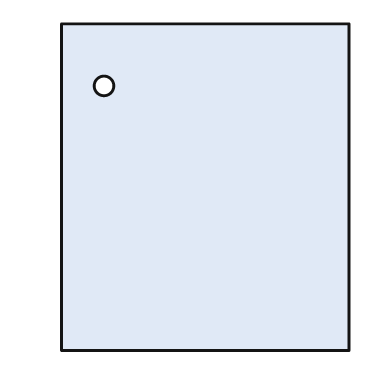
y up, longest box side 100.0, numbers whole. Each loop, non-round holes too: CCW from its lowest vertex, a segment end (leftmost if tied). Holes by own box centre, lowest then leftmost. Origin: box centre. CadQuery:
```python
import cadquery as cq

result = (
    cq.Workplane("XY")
    .moveTo(-44.0, -50.0)
    .lineTo(44.0, -50.0)
    .lineTo(44.0, 50.0)
    .lineTo(-44.0, 50.0)
    .close()
    .moveTo(-31.0, 31.0)
    .circle(3.0)
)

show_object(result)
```